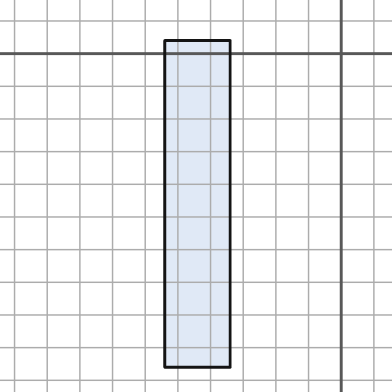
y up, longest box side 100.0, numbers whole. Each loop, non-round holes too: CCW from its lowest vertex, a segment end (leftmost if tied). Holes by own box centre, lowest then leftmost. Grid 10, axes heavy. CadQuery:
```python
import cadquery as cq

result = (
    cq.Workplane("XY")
    .moveTo(-54.0, -96.0)
    .lineTo(-34.0, -96.0)
    .lineTo(-34.0, 4.0)
    .lineTo(-54.0, 4.0)
    .close()
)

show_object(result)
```